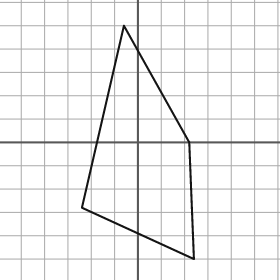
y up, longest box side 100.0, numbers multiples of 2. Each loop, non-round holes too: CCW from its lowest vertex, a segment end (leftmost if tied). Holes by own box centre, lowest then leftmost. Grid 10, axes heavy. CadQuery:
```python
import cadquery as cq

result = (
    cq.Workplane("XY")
    .moveTo(24.0, -50.0)
    .lineTo(22.0, 0.0)
    .lineTo(-6.0, 50.0)
    .lineTo(-24.0, -28.0)
    .close()
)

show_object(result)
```